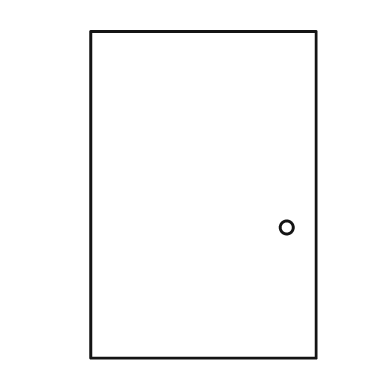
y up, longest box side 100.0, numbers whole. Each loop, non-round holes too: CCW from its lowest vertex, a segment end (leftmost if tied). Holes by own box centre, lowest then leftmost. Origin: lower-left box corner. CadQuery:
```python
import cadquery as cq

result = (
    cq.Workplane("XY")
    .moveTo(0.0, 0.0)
    .lineTo(69.0, 0.0)
    .lineTo(69.0, 100.0)
    .lineTo(0.0, 100.0)
    .close()
    .moveTo(60.0, 40.0)
    .circle(2.0)
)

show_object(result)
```